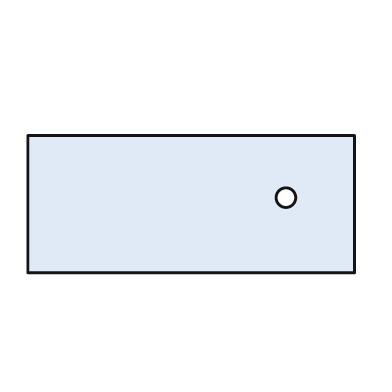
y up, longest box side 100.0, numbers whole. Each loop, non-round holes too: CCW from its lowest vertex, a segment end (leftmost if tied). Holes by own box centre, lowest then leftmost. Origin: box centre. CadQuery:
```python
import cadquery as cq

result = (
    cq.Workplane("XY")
    .moveTo(-50.0, -21.0)
    .lineTo(50.0, -21.0)
    .lineTo(50.0, 21.0)
    .lineTo(-50.0, 21.0)
    .close()
    .moveTo(29.0, 2.0)
    .circle(3.0)
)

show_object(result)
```